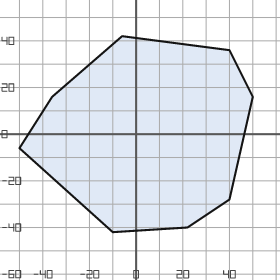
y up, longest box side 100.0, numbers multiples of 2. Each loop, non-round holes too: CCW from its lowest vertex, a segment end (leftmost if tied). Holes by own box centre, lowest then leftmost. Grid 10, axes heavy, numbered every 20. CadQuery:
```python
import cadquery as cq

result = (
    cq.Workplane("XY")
    .moveTo(-10.0, -42.0)
    .lineTo(22.0, -40.0)
    .lineTo(40.0, -28.0)
    .lineTo(50.0, 16.0)
    .lineTo(40.0, 36.0)
    .lineTo(-6.0, 42.0)
    .lineTo(-36.0, 16.0)
    .lineTo(-50.0, -6.0)
    .close()
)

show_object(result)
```